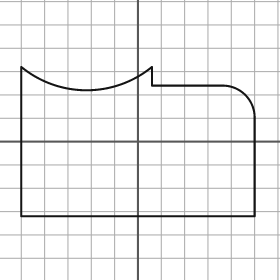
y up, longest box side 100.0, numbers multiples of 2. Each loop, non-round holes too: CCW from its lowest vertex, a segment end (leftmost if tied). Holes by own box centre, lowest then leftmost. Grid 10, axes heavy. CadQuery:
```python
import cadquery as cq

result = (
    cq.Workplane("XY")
    .moveTo(-50.0, -32.0)
    .lineTo(50.0, -32.0)
    .lineTo(50.0, 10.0)
    .threePointArc((46.0, 20.0), (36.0, 24.0))
    .lineTo(6.0, 24.0)
    .lineTo(6.0, 32.0)
    .threePointArc((-22.0, 22.0), (-50.0, 32.0))
    .close()
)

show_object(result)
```